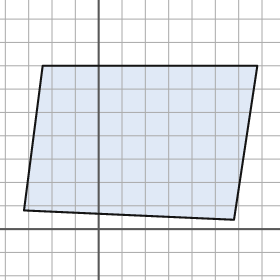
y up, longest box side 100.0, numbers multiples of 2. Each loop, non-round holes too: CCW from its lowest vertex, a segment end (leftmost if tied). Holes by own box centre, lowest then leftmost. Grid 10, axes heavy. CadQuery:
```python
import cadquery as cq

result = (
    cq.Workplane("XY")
    .moveTo(58.0, 4.0)
    .lineTo(68.0, 70.0)
    .lineTo(-24.0, 70.0)
    .lineTo(-32.0, 8.0)
    .close()
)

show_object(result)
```